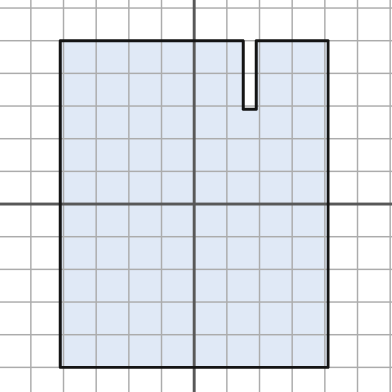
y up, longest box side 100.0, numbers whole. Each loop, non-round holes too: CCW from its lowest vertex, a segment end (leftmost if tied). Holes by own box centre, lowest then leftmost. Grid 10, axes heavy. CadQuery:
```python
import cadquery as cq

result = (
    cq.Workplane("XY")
    .moveTo(-41.0, -50.0)
    .lineTo(41.0, -50.0)
    .lineTo(41.0, 50.0)
    .lineTo(19.0, 50.0)
    .lineTo(19.0, 29.0)
    .lineTo(15.0, 29.0)
    .lineTo(15.0, 50.0)
    .lineTo(-41.0, 50.0)
    .close()
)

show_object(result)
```